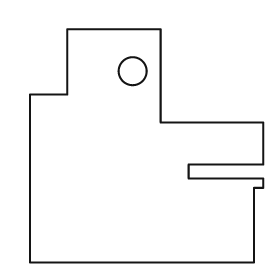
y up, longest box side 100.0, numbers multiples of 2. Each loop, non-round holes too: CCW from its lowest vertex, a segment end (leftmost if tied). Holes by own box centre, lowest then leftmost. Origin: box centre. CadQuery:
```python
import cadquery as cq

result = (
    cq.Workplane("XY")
    .moveTo(-50.0, -50.0)
    .lineTo(46.0, -50.0)
    .lineTo(46.0, -18.0)
    .lineTo(50.0, -18.0)
    .lineTo(50.0, -14.0)
    .lineTo(18.0, -14.0)
    .lineTo(18.0, -8.0)
    .lineTo(50.0, -8.0)
    .lineTo(50.0, 10.0)
    .lineTo(6.0, 10.0)
    .lineTo(6.0, 50.0)
    .lineTo(-34.0, 50.0)
    .lineTo(-34.0, 22.0)
    .lineTo(-50.0, 22.0)
    .close()
    .moveTo(-6.0, 32.0)
    .circle(6.0)
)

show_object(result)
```